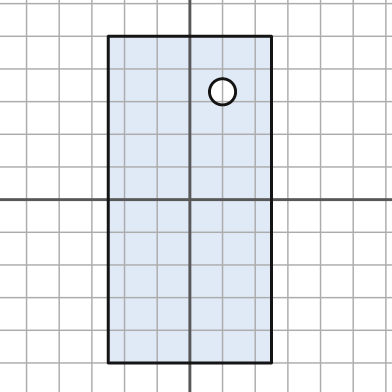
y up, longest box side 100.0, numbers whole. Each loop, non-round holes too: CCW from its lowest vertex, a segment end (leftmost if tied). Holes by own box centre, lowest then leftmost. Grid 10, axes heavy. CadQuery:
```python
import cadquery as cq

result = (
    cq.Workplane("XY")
    .moveTo(-25.0, -50.0)
    .lineTo(25.0, -50.0)
    .lineTo(25.0, 50.0)
    .lineTo(-25.0, 50.0)
    .close()
    .moveTo(10.0, 33.0)
    .circle(4.0)
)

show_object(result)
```